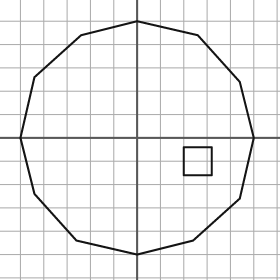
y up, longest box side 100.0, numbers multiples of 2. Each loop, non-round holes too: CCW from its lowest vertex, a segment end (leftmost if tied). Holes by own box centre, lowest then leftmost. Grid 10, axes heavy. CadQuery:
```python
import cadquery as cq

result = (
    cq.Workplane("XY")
    .moveTo(0.0, -50.0)
    .lineTo(24.0, -44.0)
    .lineTo(44.0, -26.0)
    .lineTo(50.0, 0.0)
    .lineTo(44.0, 24.0)
    .lineTo(26.0, 44.0)
    .lineTo(0.0, 50.0)
    .lineTo(-24.0, 44.0)
    .lineTo(-44.0, 26.0)
    .lineTo(-50.0, 0.0)
    .lineTo(-44.0, -24.0)
    .lineTo(-26.0, -44.0)
    .close()
    .moveTo(20.0, -16.0)
    .lineTo(32.0, -16.0)
    .lineTo(32.0, -4.0)
    .lineTo(20.0, -4.0)
    .close()
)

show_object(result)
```